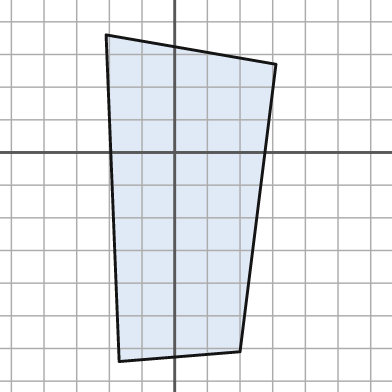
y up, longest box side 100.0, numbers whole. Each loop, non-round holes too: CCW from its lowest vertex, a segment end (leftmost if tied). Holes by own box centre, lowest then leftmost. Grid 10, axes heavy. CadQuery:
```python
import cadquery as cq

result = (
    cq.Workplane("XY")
    .moveTo(-17.0, -64.0)
    .lineTo(20.0, -61.0)
    .lineTo(31.0, 27.0)
    .lineTo(-21.0, 36.0)
    .close()
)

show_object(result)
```